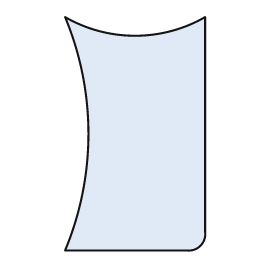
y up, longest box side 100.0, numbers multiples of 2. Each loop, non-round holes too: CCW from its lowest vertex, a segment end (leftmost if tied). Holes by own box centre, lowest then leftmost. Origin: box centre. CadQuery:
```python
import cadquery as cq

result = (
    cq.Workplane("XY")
    .moveTo(-30.0, -50.0)
    .lineTo(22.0, -50.0)
    .threePointArc((28.0, -48.0), (30.0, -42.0))
    .lineTo(30.0, 50.0)
    .threePointArc((0.0, 42.0), (-30.0, 50.0))
    .threePointArc((-20.0, 0.0), (-30.0, -50.0))
    .close()
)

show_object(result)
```